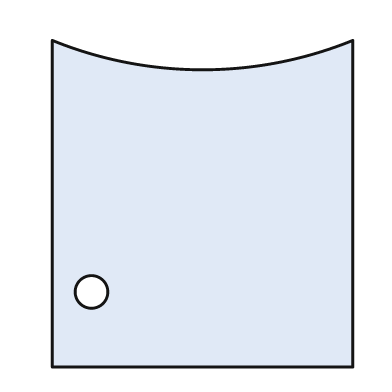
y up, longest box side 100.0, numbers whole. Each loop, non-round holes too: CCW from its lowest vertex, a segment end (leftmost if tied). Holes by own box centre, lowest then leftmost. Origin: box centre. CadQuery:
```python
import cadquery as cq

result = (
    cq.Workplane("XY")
    .moveTo(-46.0, -50.0)
    .lineTo(46.0, -50.0)
    .lineTo(46.0, 50.0)
    .threePointArc((0.0, 41.0), (-46.0, 50.0))
    .close()
    .moveTo(-34.0, -27.0)
    .circle(5.0)
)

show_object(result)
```